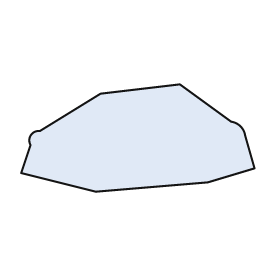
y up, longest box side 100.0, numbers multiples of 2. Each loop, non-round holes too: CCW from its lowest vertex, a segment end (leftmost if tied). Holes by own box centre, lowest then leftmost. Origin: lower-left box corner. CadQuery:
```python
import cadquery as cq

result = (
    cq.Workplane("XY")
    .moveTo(32.0, 0.0)
    .lineTo(80.0, 4.0)
    .lineTo(100.0, 10.0)
    .lineTo(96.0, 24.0)
    .threePointArc((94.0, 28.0), (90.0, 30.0))
    .lineTo(68.0, 46.0)
    .lineTo(34.0, 42.0)
    .lineTo(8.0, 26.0)
    .threePointArc((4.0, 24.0), (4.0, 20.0))
    .lineTo(0.0, 8.0)
    .close()
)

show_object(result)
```